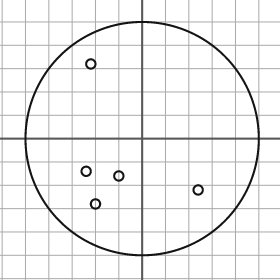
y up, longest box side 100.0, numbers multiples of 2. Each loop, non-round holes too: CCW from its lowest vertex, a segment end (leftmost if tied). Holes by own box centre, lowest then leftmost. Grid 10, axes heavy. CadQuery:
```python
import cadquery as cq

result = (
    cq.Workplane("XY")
    .moveTo(0.0, 0.0)
    .circle(50.0)
    .moveTo(-20.0, -28.0)
    .circle(2.0)
    .moveTo(24.0, -22.0)
    .circle(2.0)
    .moveTo(-10.0, -16.0)
    .circle(2.0)
    .moveTo(-24.0, -14.0)
    .circle(2.0)
    .moveTo(-22.0, 32.0)
    .circle(2.0)
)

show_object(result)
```